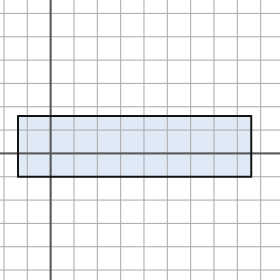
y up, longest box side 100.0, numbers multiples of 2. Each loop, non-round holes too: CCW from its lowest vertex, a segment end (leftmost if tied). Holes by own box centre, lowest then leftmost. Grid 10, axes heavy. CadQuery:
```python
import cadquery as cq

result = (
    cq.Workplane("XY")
    .moveTo(-14.0, -10.0)
    .lineTo(86.0, -10.0)
    .lineTo(86.0, 16.0)
    .lineTo(-14.0, 16.0)
    .close()
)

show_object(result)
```